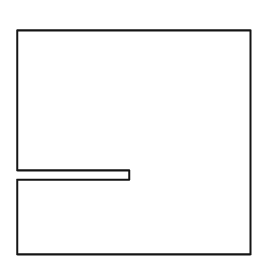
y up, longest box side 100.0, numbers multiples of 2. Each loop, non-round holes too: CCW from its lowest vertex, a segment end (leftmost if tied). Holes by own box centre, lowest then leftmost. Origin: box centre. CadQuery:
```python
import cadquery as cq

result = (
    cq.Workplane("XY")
    .moveTo(-50.0, -48.0)
    .lineTo(50.0, -48.0)
    .lineTo(50.0, 48.0)
    .lineTo(-50.0, 48.0)
    .lineTo(-50.0, -12.0)
    .lineTo(-2.0, -12.0)
    .lineTo(-2.0, -16.0)
    .lineTo(-50.0, -16.0)
    .close()
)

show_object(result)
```